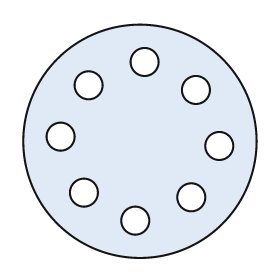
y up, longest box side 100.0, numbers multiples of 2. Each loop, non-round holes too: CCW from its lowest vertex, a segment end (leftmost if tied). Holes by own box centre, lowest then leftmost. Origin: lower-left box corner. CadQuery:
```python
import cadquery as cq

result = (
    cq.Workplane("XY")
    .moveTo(50.0, 50.0)
    .circle(50.0)
    .moveTo(48.0, 16.0)
    .circle(6.0)
    .moveTo(72.0, 26.0)
    .circle(6.0)
    .moveTo(26.0, 28.0)
    .circle(6.0)
    .moveTo(84.0, 48.0)
    .circle(6.0)
    .moveTo(16.0, 52.0)
    .circle(6.0)
    .moveTo(74.0, 72.0)
    .circle(6.0)
    .moveTo(28.0, 74.0)
    .circle(6.0)
    .moveTo(52.0, 84.0)
    .circle(6.0)
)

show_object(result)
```